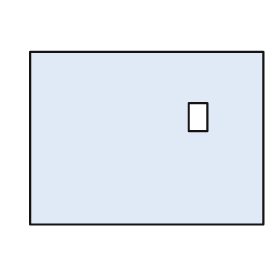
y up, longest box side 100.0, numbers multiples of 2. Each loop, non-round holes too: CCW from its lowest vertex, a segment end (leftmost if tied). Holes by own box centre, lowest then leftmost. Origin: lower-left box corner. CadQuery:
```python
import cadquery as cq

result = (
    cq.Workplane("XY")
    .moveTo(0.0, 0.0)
    .lineTo(100.0, 0.0)
    .lineTo(100.0, 74.0)
    .lineTo(0.0, 74.0)
    .close()
    .moveTo(68.0, 40.0)
    .lineTo(76.0, 40.0)
    .lineTo(76.0, 52.0)
    .lineTo(68.0, 52.0)
    .close()
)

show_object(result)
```